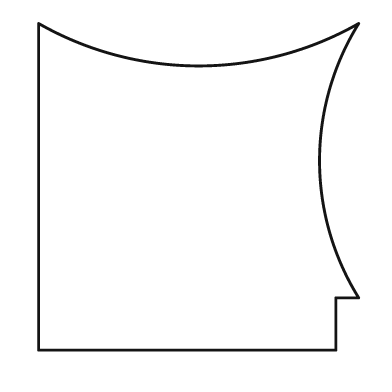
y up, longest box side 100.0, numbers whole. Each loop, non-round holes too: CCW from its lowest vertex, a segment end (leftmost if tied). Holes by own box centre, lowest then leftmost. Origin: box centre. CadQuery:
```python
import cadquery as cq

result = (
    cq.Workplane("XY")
    .moveTo(-49.0, -50.0)
    .lineTo(42.0, -50.0)
    .lineTo(42.0, -34.0)
    .lineTo(49.0, -34.0)
    .threePointArc((37.0, 8.0), (49.0, 50.0))
    .threePointArc((0.0, 37.0), (-49.0, 50.0))
    .close()
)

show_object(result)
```